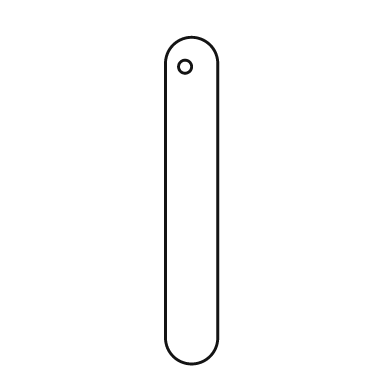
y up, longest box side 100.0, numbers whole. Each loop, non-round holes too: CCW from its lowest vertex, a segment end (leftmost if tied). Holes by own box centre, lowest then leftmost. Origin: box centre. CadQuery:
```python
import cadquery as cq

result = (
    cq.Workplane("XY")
    .moveTo(-8.0, -42.0)
    .threePointArc((0.0, -50.0), (8.0, -42.0))
    .lineTo(8.0, 42.0)
    .threePointArc((0.0, 50.0), (-8.0, 42.0))
    .close()
    .moveTo(-2.0, 41.0)
    .circle(2.0)
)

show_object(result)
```